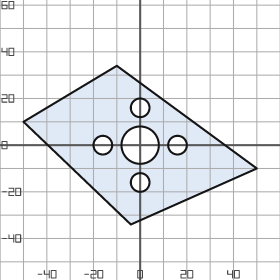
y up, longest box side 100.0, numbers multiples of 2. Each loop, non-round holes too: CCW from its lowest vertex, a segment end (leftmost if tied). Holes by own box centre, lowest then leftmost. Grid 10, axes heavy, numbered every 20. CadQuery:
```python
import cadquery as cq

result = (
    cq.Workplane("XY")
    .moveTo(-4.0, -34.0)
    .lineTo(50.0, -10.0)
    .lineTo(-10.0, 34.0)
    .lineTo(-50.0, 10.0)
    .close()
    .moveTo(0.0, -16.0)
    .circle(4.0)
    .moveTo(-16.0, 0.0)
    .circle(4.0)
    .moveTo(0.0, 0.0)
    .circle(8.0)
    .moveTo(16.0, 0.0)
    .circle(4.0)
    .moveTo(0.0, 16.0)
    .circle(4.0)
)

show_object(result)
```